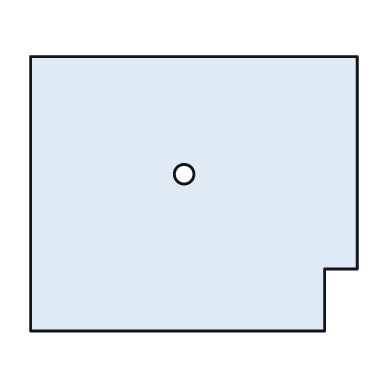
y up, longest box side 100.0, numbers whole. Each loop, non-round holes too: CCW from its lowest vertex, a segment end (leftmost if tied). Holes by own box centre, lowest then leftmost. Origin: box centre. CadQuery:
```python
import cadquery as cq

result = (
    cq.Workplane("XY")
    .moveTo(-50.0, -42.0)
    .lineTo(40.0, -42.0)
    .lineTo(40.0, -23.0)
    .lineTo(50.0, -23.0)
    .lineTo(50.0, 42.0)
    .lineTo(-50.0, 42.0)
    .close()
    .moveTo(-3.0, 6.0)
    .circle(3.0)
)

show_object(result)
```